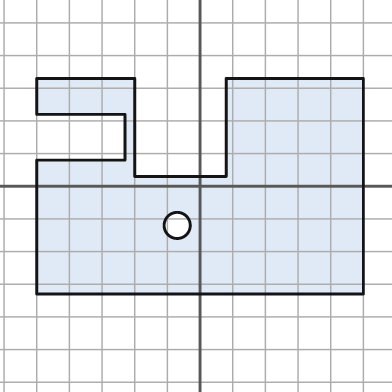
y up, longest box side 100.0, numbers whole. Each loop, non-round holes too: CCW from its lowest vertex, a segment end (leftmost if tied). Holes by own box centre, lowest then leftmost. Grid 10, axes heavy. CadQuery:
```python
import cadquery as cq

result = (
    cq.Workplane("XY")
    .moveTo(-50.0, -33.0)
    .lineTo(50.0, -33.0)
    .lineTo(50.0, 33.0)
    .lineTo(8.0, 33.0)
    .lineTo(8.0, 3.0)
    .lineTo(-20.0, 3.0)
    .lineTo(-20.0, 33.0)
    .lineTo(-50.0, 33.0)
    .lineTo(-50.0, 22.0)
    .lineTo(-23.0, 22.0)
    .lineTo(-23.0, 8.0)
    .lineTo(-50.0, 8.0)
    .close()
    .moveTo(-7.0, -12.0)
    .circle(4.0)
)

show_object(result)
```